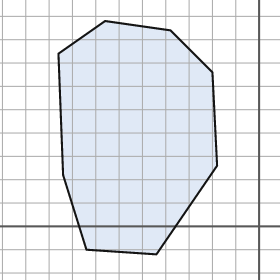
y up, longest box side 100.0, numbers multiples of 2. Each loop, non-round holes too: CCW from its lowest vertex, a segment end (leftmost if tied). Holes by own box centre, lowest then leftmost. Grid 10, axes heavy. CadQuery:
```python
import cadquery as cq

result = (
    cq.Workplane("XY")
    .moveTo(-44.0, -12.0)
    .lineTo(-18.0, 26.0)
    .lineTo(-20.0, 66.0)
    .lineTo(-38.0, 84.0)
    .lineTo(-66.0, 88.0)
    .lineTo(-86.0, 74.0)
    .lineTo(-84.0, 22.0)
    .lineTo(-74.0, -10.0)
    .close()
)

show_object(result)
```